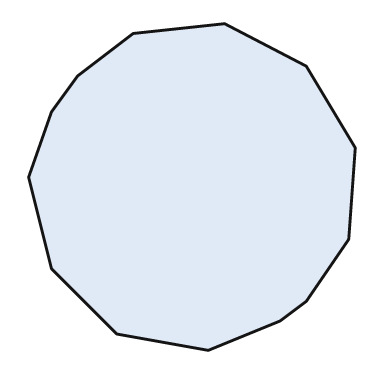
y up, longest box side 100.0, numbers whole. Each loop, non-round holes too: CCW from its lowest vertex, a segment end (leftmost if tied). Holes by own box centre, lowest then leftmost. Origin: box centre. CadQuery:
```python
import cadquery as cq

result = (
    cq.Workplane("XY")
    .moveTo(5.0, -50.0)
    .lineTo(27.0, -41.0)
    .lineTo(35.0, -35.0)
    .lineTo(48.0, -16.0)
    .lineTo(50.0, 12.0)
    .lineTo(35.0, 37.0)
    .lineTo(10.0, 50.0)
    .lineTo(-18.0, 47.0)
    .lineTo(-35.0, 34.0)
    .lineTo(-43.0, 23.0)
    .lineTo(-50.0, 3.0)
    .lineTo(-43.0, -25.0)
    .lineTo(-23.0, -45.0)
    .close()
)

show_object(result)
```